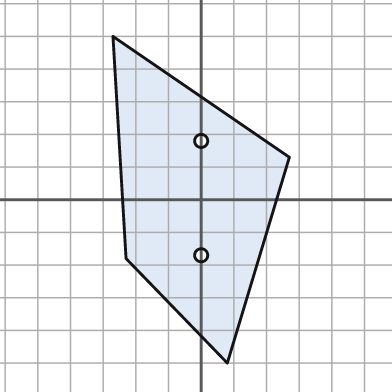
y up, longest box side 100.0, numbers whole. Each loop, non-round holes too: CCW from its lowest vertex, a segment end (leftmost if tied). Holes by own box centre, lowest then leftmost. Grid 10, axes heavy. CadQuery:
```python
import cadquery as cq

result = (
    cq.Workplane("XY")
    .moveTo(8.0, -50.0)
    .lineTo(27.0, 13.0)
    .lineTo(-27.0, 50.0)
    .lineTo(-23.0, -18.0)
    .close()
    .moveTo(0.0, -17.0)
    .circle(2.0)
    .moveTo(0.0, 18.0)
    .circle(2.0)
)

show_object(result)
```